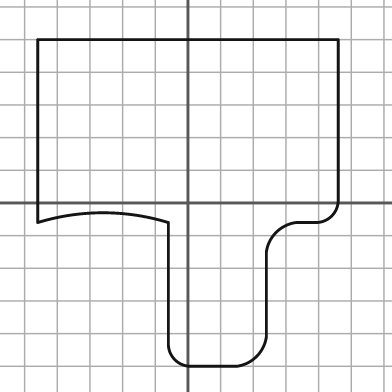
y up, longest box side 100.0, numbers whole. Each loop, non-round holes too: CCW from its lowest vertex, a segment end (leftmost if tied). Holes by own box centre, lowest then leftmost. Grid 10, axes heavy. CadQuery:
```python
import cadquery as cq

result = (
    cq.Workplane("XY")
    .moveTo(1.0, -50.0)
    .lineTo(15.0, -50.0)
    .threePointArc((21.0, -47.0), (24.0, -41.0))
    .lineTo(24.0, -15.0)
    .threePointArc((27.0, -9.0), (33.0, -6.0))
    .lineTo(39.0, -6.0)
    .threePointArc((44.0, -4.0), (46.0, 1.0))
    .lineTo(46.0, 50.0)
    .lineTo(-46.0, 50.0)
    .lineTo(-46.0, -6.0)
    .threePointArc((-26.0, -3.0), (-6.0, -6.0))
    .lineTo(-6.0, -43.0)
    .threePointArc((-4.0, -48.0), (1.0, -50.0))
    .close()
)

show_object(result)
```